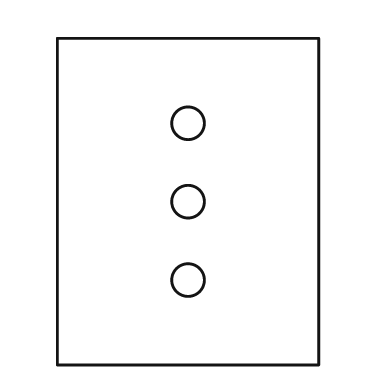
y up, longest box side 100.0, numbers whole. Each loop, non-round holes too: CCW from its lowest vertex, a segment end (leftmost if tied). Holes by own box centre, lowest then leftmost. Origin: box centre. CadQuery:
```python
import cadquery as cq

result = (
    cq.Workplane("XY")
    .moveTo(-40.0, -50.0)
    .lineTo(40.0, -50.0)
    .lineTo(40.0, 50.0)
    .lineTo(-40.0, 50.0)
    .close()
    .moveTo(0.0, -24.0)
    .circle(5.0)
    .moveTo(0.0, 0.0)
    .circle(5.0)
    .moveTo(0.0, 24.0)
    .circle(5.0)
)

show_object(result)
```